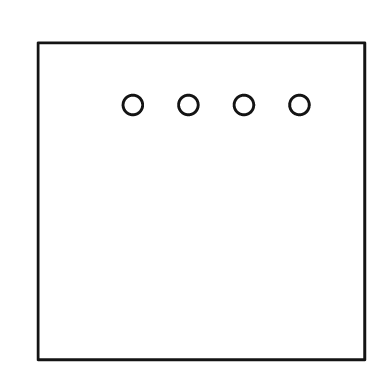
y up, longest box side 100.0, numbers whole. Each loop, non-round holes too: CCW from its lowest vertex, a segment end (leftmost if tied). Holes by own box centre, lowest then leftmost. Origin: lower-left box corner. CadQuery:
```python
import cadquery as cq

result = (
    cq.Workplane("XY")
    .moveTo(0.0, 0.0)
    .lineTo(100.0, 0.0)
    .lineTo(100.0, 97.0)
    .lineTo(0.0, 97.0)
    .close()
    .moveTo(29.0, 78.0)
    .circle(3.0)
    .moveTo(46.0, 78.0)
    .circle(3.0)
    .moveTo(63.0, 78.0)
    .circle(3.0)
    .moveTo(80.0, 78.0)
    .circle(3.0)
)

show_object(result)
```